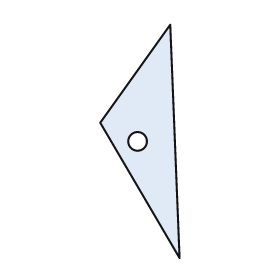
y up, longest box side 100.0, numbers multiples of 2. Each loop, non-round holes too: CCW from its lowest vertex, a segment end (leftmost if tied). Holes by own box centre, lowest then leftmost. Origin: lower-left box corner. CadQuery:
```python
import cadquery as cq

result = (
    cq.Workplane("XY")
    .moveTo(34.0, 0.0)
    .lineTo(30.0, 100.0)
    .lineTo(0.0, 58.0)
    .close()
    .moveTo(16.0, 50.0)
    .circle(4.0)
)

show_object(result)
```